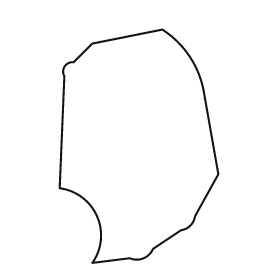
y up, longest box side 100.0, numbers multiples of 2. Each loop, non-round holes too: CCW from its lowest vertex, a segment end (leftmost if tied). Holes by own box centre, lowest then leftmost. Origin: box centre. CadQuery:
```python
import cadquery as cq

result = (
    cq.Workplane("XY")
    .moveTo(-20.0, -50.0)
    .lineTo(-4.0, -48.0)
    .threePointArc((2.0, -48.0), (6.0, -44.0))
    .lineTo(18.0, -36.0)
    .threePointArc((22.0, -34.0), (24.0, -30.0))
    .lineTo(34.0, -12.0)
    .lineTo(28.0, 22.0)
    .threePointArc((22.0, 38.0), (10.0, 50.0))
    .lineTo(-20.0, 44.0)
    .lineTo(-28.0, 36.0)
    .threePointArc((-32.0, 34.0), (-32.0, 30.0))
    .lineTo(-34.0, -18.0)
    .threePointArc((-18.0, -30.0), (-20.0, -50.0))
    .close()
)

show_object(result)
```